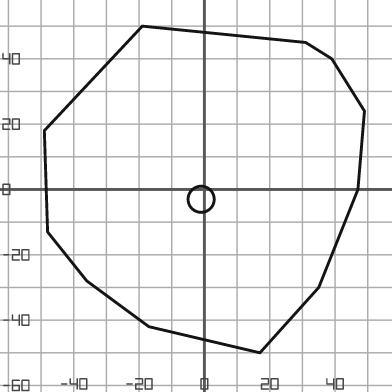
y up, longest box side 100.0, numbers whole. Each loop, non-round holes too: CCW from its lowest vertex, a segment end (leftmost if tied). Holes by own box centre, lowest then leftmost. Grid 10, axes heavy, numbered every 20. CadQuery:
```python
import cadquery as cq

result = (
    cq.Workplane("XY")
    .moveTo(17.0, -50.0)
    .lineTo(35.0, -30.0)
    .lineTo(47.0, 0.0)
    .lineTo(49.0, 24.0)
    .lineTo(39.0, 40.0)
    .lineTo(31.0, 45.0)
    .lineTo(-19.0, 50.0)
    .lineTo(-49.0, 18.0)
    .lineTo(-48.0, -13.0)
    .lineTo(-36.0, -28.0)
    .lineTo(-17.0, -42.0)
    .close()
    .moveTo(-1.0, -3.0)
    .circle(4.0)
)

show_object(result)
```